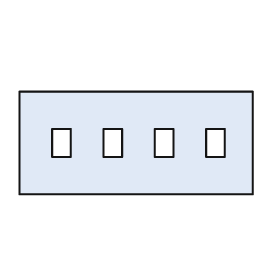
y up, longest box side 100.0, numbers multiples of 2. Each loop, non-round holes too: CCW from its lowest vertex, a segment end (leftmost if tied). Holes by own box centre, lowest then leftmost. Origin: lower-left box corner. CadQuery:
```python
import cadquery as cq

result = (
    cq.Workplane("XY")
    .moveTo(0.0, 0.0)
    .lineTo(100.0, 0.0)
    .lineTo(100.0, 44.0)
    .lineTo(0.0, 44.0)
    .close()
    .moveTo(14.0, 16.0)
    .lineTo(22.0, 16.0)
    .lineTo(22.0, 28.0)
    .lineTo(14.0, 28.0)
    .close()
    .moveTo(36.0, 16.0)
    .lineTo(44.0, 16.0)
    .lineTo(44.0, 28.0)
    .lineTo(36.0, 28.0)
    .close()
    .moveTo(58.0, 16.0)
    .lineTo(66.0, 16.0)
    .lineTo(66.0, 28.0)
    .lineTo(58.0, 28.0)
    .close()
    .moveTo(80.0, 16.0)
    .lineTo(88.0, 16.0)
    .lineTo(88.0, 28.0)
    .lineTo(80.0, 28.0)
    .close()
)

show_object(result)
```